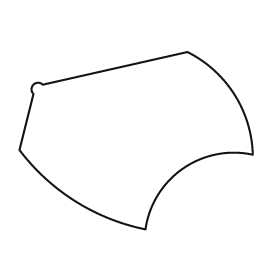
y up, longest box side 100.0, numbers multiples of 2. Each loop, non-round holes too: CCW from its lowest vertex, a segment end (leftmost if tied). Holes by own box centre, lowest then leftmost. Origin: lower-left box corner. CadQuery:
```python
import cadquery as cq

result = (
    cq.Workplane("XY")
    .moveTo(54.0, 0.0)
    .threePointArc((70.0, 26.0), (100.0, 32.0))
    .threePointArc((92.0, 58.0), (72.0, 76.0))
    .lineTo(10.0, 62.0)
    .threePointArc((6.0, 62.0), (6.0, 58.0))
    .lineTo(0.0, 34.0)
    .threePointArc((24.0, 12.0), (54.0, 0.0))
    .close()
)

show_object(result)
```